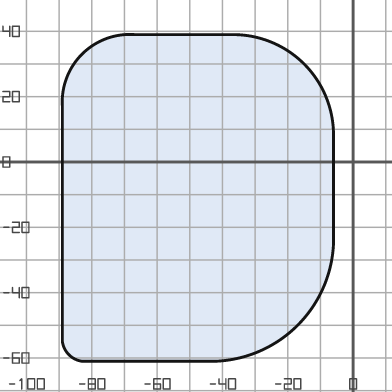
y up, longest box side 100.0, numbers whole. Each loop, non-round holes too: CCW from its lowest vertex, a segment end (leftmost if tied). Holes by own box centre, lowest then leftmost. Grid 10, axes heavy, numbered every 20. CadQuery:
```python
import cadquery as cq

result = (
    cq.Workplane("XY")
    .moveTo(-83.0, -61.0)
    .lineTo(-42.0, -61.0)
    .threePointArc((-17.0, -50.0), (-6.0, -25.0))
    .lineTo(-6.0, 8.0)
    .threePointArc((-15.0, 30.0), (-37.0, 39.0))
    .lineTo(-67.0, 39.0)
    .threePointArc((-83.0, 33.0), (-89.0, 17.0))
    .lineTo(-89.0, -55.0)
    .threePointArc((-87.0, -59.0), (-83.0, -61.0))
    .close()
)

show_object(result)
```